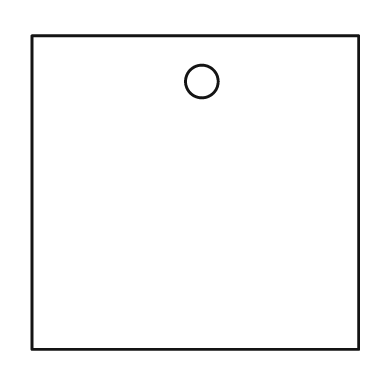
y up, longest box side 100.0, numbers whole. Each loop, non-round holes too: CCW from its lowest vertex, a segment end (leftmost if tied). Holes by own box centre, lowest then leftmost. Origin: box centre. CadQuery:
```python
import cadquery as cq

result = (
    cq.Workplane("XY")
    .moveTo(-50.0, -48.0)
    .lineTo(50.0, -48.0)
    .lineTo(50.0, 48.0)
    .lineTo(-50.0, 48.0)
    .close()
    .moveTo(2.0, 34.0)
    .circle(5.0)
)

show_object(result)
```